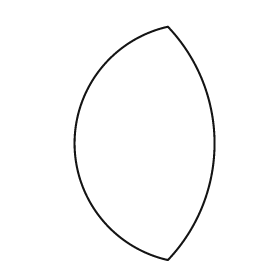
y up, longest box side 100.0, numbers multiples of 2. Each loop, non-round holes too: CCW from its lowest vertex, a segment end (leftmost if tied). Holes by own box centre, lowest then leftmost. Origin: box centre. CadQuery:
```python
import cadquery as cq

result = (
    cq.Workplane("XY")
    .moveTo(10.0, -50.0)
    .threePointArc((30.0, 0.0), (10.0, 50.0))
    .threePointArc((-30.0, 0.0), (10.0, -50.0))
    .close()
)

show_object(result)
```